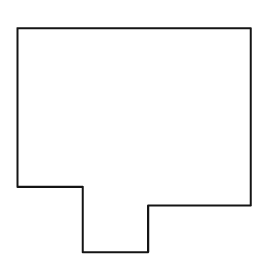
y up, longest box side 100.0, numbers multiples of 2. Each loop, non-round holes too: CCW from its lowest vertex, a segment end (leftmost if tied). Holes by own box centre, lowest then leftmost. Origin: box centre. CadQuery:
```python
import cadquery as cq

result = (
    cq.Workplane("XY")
    .moveTo(-22.0, -48.0)
    .lineTo(6.0, -48.0)
    .lineTo(6.0, -28.0)
    .lineTo(50.0, -28.0)
    .lineTo(50.0, 48.0)
    .lineTo(-50.0, 48.0)
    .lineTo(-50.0, -20.0)
    .lineTo(-22.0, -20.0)
    .close()
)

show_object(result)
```